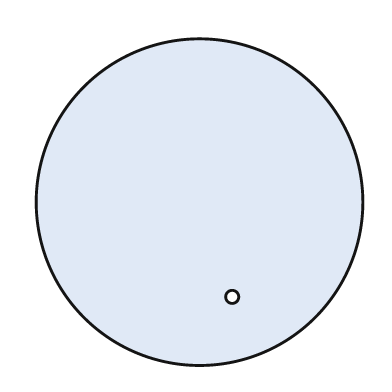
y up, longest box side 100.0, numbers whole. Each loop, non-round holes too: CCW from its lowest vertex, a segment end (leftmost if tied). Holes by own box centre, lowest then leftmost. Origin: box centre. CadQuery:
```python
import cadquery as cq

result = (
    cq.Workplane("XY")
    .moveTo(0.0, 0.0)
    .circle(50.0)
    .moveTo(10.0, -29.0)
    .circle(2.0)
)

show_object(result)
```